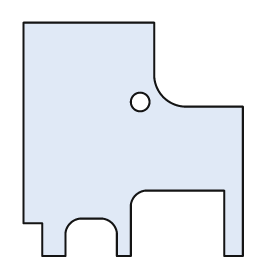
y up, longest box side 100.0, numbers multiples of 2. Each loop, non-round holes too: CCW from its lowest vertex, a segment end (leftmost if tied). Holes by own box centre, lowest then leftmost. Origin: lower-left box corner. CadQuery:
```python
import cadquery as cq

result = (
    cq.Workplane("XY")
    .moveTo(8.0, 0.0)
    .lineTo(18.0, 0.0)
    .lineTo(18.0, 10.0)
    .threePointArc((20.0, 14.0), (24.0, 16.0))
    .lineTo(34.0, 16.0)
    .threePointArc((38.0, 14.0), (40.0, 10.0))
    .lineTo(40.0, 0.0)
    .lineTo(46.0, 0.0)
    .lineTo(46.0, 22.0)
    .threePointArc((48.0, 26.0), (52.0, 28.0))
    .lineTo(86.0, 28.0)
    .lineTo(86.0, 0.0)
    .lineTo(94.0, 0.0)
    .lineTo(94.0, 64.0)
    .lineTo(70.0, 64.0)
    .threePointArc((60.0, 68.0), (56.0, 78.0))
    .lineTo(56.0, 100.0)
    .lineTo(0.0, 100.0)
    .lineTo(0.0, 14.0)
    .lineTo(8.0, 14.0)
    .close()
    .moveTo(50.0, 66.0)
    .circle(4.0)
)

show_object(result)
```